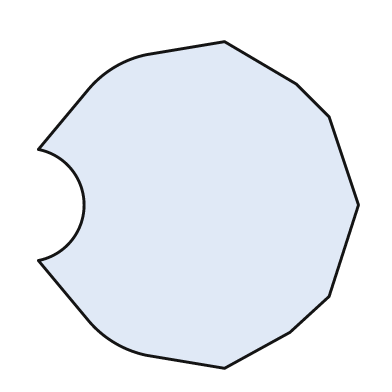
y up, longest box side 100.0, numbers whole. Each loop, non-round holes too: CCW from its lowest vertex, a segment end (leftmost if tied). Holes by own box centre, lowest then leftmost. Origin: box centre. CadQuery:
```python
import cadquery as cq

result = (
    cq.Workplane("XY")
    .moveTo(8.0, -50.0)
    .lineTo(28.0, -39.0)
    .lineTo(40.0, -28.0)
    .lineTo(49.0, 0.0)
    .lineTo(40.0, 27.0)
    .lineTo(30.0, 37.0)
    .lineTo(8.0, 50.0)
    .lineTo(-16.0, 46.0)
    .threePointArc((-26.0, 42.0), (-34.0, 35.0))
    .lineTo(-49.0, 17.0)
    .threePointArc((-35.0, 0.0), (-49.0, -17.0))
    .lineTo(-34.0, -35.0)
    .threePointArc((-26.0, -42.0), (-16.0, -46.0))
    .close()
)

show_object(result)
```